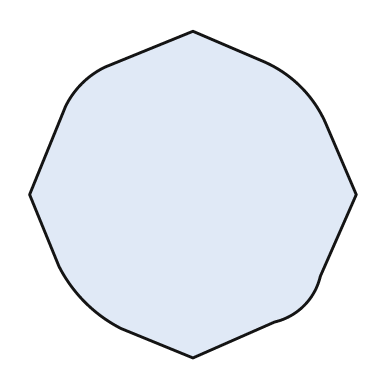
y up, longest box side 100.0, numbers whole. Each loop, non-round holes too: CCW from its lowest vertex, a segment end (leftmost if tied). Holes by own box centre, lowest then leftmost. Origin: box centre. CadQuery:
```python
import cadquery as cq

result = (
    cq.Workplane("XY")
    .moveTo(0.0, -50.0)
    .lineTo(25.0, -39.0)
    .threePointArc((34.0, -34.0), (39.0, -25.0))
    .lineTo(50.0, 0.0)
    .lineTo(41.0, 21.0)
    .threePointArc((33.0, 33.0), (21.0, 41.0))
    .lineTo(0.0, 50.0)
    .lineTo(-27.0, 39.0)
    .threePointArc((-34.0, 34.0), (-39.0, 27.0))
    .lineTo(-50.0, 0.0)
    .lineTo(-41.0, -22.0)
    .threePointArc((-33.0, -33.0), (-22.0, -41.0))
    .close()
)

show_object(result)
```